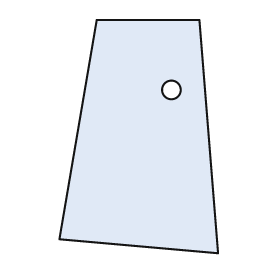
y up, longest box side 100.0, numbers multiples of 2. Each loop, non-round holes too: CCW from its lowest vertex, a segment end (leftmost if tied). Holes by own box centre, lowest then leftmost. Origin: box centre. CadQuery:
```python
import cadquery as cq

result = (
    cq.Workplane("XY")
    .moveTo(34.0, -50.0)
    .lineTo(26.0, 50.0)
    .lineTo(-18.0, 50.0)
    .lineTo(-34.0, -44.0)
    .close()
    .moveTo(14.0, 20.0)
    .circle(4.0)
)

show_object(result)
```